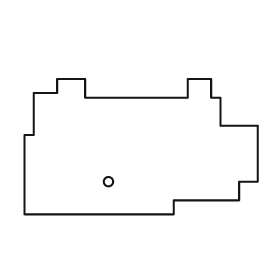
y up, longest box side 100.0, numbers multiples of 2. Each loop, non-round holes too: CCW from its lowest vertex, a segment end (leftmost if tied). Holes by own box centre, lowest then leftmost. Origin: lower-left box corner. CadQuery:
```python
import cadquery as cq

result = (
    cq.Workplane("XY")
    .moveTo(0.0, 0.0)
    .lineTo(64.0, 0.0)
    .lineTo(64.0, 6.0)
    .lineTo(92.0, 6.0)
    .lineTo(92.0, 14.0)
    .lineTo(100.0, 14.0)
    .lineTo(100.0, 38.0)
    .lineTo(84.0, 38.0)
    .lineTo(84.0, 50.0)
    .lineTo(80.0, 50.0)
    .lineTo(80.0, 58.0)
    .lineTo(70.0, 58.0)
    .lineTo(70.0, 50.0)
    .lineTo(26.0, 50.0)
    .lineTo(26.0, 58.0)
    .lineTo(14.0, 58.0)
    .lineTo(14.0, 52.0)
    .lineTo(4.0, 52.0)
    .lineTo(4.0, 34.0)
    .lineTo(0.0, 34.0)
    .close()
    .moveTo(36.0, 14.0)
    .circle(2.0)
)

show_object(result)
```